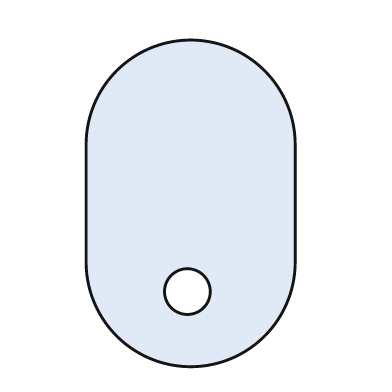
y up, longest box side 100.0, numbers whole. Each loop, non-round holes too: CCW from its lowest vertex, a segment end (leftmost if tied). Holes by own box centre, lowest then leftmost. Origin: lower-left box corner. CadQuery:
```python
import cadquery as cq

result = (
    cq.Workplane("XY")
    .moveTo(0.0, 32.0)
    .threePointArc((32.0, 0.0), (64.0, 32.0))
    .lineTo(64.0, 68.0)
    .threePointArc((32.0, 100.0), (0.0, 68.0))
    .close()
    .moveTo(31.0, 23.0)
    .circle(7.0)
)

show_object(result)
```